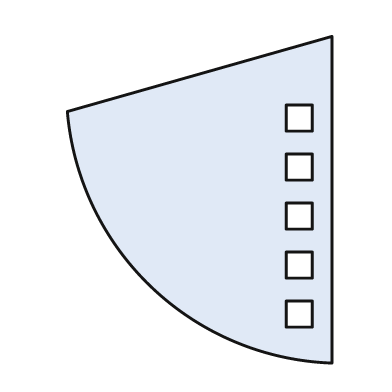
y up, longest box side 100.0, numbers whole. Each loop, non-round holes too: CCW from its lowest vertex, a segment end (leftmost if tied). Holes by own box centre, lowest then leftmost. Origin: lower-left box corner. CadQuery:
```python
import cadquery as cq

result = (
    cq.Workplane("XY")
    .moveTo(81.0, 0.0)
    .lineTo(81.0, 100.0)
    .lineTo(0.0, 77.0)
    .threePointArc((26.0, 23.0), (81.0, 0.0))
    .close()
    .moveTo(67.0, 11.0)
    .lineTo(75.0, 11.0)
    .lineTo(75.0, 19.0)
    .lineTo(67.0, 19.0)
    .close()
    .moveTo(67.0, 26.0)
    .lineTo(75.0, 26.0)
    .lineTo(75.0, 34.0)
    .lineTo(67.0, 34.0)
    .close()
    .moveTo(67.0, 41.0)
    .lineTo(75.0, 41.0)
    .lineTo(75.0, 49.0)
    .lineTo(67.0, 49.0)
    .close()
    .moveTo(67.0, 56.0)
    .lineTo(75.0, 56.0)
    .lineTo(75.0, 64.0)
    .lineTo(67.0, 64.0)
    .close()
    .moveTo(67.0, 71.0)
    .lineTo(75.0, 71.0)
    .lineTo(75.0, 79.0)
    .lineTo(67.0, 79.0)
    .close()
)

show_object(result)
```